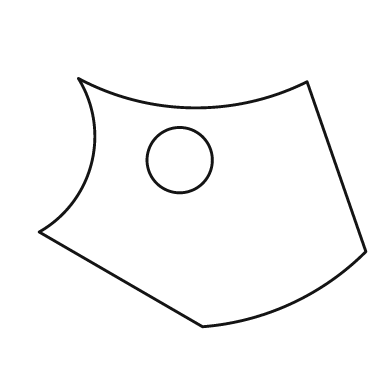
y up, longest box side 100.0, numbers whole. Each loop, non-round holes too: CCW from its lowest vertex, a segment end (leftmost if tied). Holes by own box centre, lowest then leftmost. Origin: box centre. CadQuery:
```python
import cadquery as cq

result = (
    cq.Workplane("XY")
    .moveTo(0.0, -38.0)
    .threePointArc((27.0, -31.0), (50.0, -15.0))
    .lineTo(32.0, 37.0)
    .threePointArc((-3.0, 29.0), (-38.0, 38.0))
    .threePointArc((-34.0, 12.0), (-50.0, -9.0))
    .close()
    .moveTo(-7.0, 13.0)
    .circle(10.0)
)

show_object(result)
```